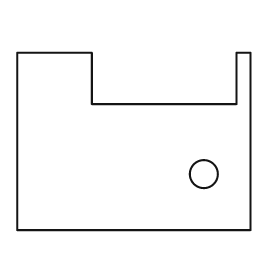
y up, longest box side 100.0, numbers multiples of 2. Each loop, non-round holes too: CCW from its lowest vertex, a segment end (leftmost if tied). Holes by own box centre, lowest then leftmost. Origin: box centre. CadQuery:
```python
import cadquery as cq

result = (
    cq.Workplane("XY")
    .moveTo(-50.0, -38.0)
    .lineTo(50.0, -38.0)
    .lineTo(50.0, 38.0)
    .lineTo(44.0, 38.0)
    .lineTo(44.0, 16.0)
    .lineTo(-18.0, 16.0)
    .lineTo(-18.0, 38.0)
    .lineTo(-50.0, 38.0)
    .close()
    .moveTo(30.0, -14.0)
    .circle(6.0)
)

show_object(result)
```